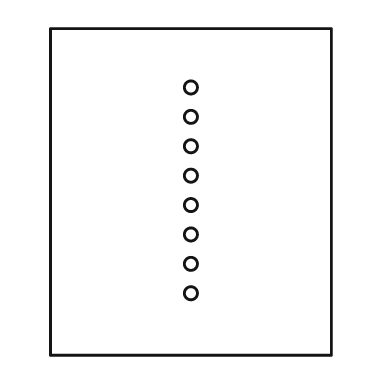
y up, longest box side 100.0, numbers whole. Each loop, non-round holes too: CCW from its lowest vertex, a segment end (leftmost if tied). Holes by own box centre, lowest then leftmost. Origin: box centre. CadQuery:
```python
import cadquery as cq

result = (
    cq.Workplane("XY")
    .moveTo(-43.0, -50.0)
    .lineTo(43.0, -50.0)
    .lineTo(43.0, 50.0)
    .lineTo(-43.0, 50.0)
    .close()
    .moveTo(0.0, -31.0)
    .circle(2.0)
    .moveTo(0.0, -22.0)
    .circle(2.0)
    .moveTo(0.0, -13.0)
    .circle(2.0)
    .moveTo(0.0, -4.0)
    .circle(2.0)
    .moveTo(0.0, 5.0)
    .circle(2.0)
    .moveTo(0.0, 14.0)
    .circle(2.0)
    .moveTo(0.0, 23.0)
    .circle(2.0)
    .moveTo(0.0, 32.0)
    .circle(2.0)
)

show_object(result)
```